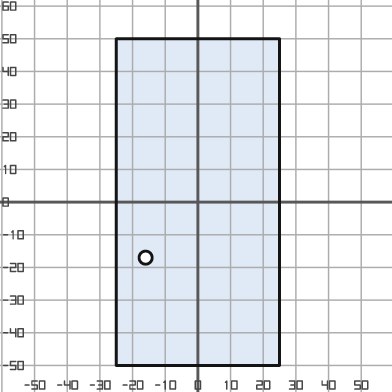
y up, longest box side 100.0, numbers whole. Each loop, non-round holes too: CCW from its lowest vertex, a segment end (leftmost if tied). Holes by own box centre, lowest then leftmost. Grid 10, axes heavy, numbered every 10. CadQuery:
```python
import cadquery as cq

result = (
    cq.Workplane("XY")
    .moveTo(-25.0, -50.0)
    .lineTo(25.0, -50.0)
    .lineTo(25.0, 50.0)
    .lineTo(-25.0, 50.0)
    .close()
    .moveTo(-16.0, -17.0)
    .circle(2.0)
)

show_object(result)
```